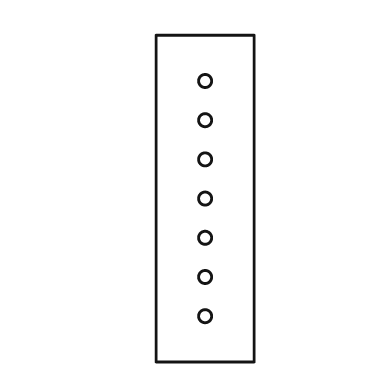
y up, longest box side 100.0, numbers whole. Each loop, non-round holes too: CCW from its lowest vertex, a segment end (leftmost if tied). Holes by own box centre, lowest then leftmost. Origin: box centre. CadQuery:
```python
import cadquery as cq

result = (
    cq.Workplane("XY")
    .moveTo(-15.0, -50.0)
    .lineTo(15.0, -50.0)
    .lineTo(15.0, 50.0)
    .lineTo(-15.0, 50.0)
    .close()
    .moveTo(0.0, -36.0)
    .circle(2.0)
    .moveTo(0.0, -24.0)
    .circle(2.0)
    .moveTo(0.0, -12.0)
    .circle(2.0)
    .moveTo(0.0, 0.0)
    .circle(2.0)
    .moveTo(0.0, 12.0)
    .circle(2.0)
    .moveTo(0.0, 24.0)
    .circle(2.0)
    .moveTo(0.0, 36.0)
    .circle(2.0)
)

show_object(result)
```